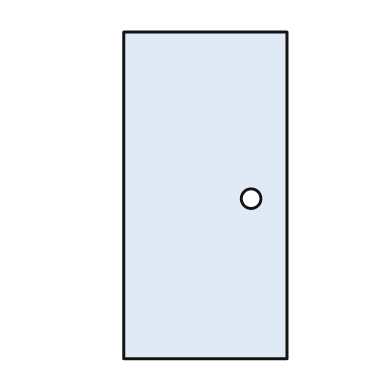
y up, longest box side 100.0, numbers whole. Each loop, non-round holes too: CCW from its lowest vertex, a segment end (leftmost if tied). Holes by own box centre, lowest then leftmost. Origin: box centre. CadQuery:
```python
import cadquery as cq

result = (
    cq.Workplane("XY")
    .moveTo(-25.0, -50.0)
    .lineTo(25.0, -50.0)
    .lineTo(25.0, 50.0)
    .lineTo(-25.0, 50.0)
    .close()
    .moveTo(14.0, -1.0)
    .circle(3.0)
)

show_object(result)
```